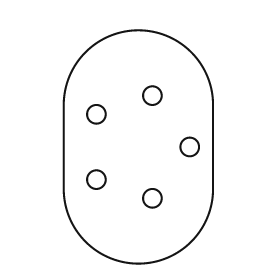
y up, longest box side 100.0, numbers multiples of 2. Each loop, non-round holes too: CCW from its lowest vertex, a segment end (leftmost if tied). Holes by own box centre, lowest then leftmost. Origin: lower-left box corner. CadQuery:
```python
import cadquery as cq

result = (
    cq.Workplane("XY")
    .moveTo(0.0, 32.0)
    .threePointArc((32.0, 0.0), (64.0, 32.0))
    .lineTo(64.0, 68.0)
    .threePointArc((32.0, 100.0), (0.0, 68.0))
    .close()
    .moveTo(38.0, 28.0)
    .circle(4.0)
    .moveTo(14.0, 36.0)
    .circle(4.0)
    .moveTo(54.0, 50.0)
    .circle(4.0)
    .moveTo(14.0, 64.0)
    .circle(4.0)
    .moveTo(38.0, 72.0)
    .circle(4.0)
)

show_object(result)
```